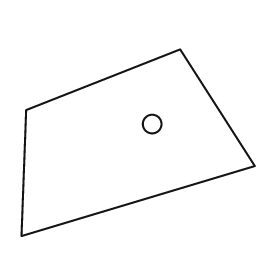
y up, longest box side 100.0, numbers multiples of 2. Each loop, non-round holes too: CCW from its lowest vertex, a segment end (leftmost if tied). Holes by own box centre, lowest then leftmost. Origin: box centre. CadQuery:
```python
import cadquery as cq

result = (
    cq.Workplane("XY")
    .moveTo(-50.0, -40.0)
    .lineTo(50.0, -10.0)
    .lineTo(18.0, 40.0)
    .lineTo(-48.0, 14.0)
    .close()
    .moveTo(6.0, 8.0)
    .circle(4.0)
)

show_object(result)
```